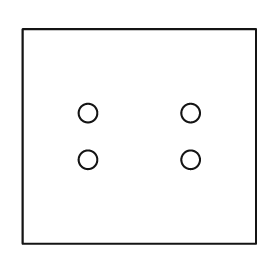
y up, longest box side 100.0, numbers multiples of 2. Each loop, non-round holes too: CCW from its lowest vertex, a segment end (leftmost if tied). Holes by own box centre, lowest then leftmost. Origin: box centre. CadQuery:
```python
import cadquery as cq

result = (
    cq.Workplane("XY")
    .moveTo(-50.0, -46.0)
    .lineTo(50.0, -46.0)
    .lineTo(50.0, 46.0)
    .lineTo(-50.0, 46.0)
    .close()
    .moveTo(-22.0, -10.0)
    .circle(4.0)
    .moveTo(22.0, -10.0)
    .circle(4.0)
    .moveTo(-22.0, 10.0)
    .circle(4.0)
    .moveTo(22.0, 10.0)
    .circle(4.0)
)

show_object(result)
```